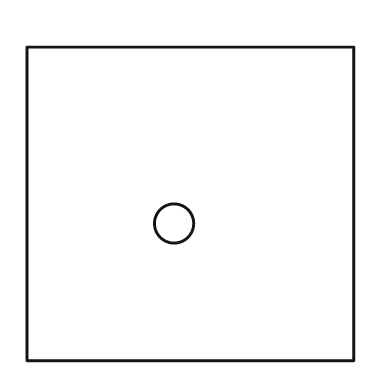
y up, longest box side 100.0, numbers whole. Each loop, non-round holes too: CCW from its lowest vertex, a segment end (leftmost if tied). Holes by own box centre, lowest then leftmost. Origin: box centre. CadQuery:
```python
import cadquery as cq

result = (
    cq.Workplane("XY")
    .moveTo(-50.0, -48.0)
    .lineTo(50.0, -48.0)
    .lineTo(50.0, 48.0)
    .lineTo(-50.0, 48.0)
    .close()
    .moveTo(-5.0, -6.0)
    .circle(6.0)
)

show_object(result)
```